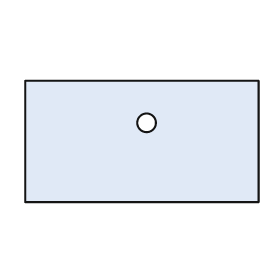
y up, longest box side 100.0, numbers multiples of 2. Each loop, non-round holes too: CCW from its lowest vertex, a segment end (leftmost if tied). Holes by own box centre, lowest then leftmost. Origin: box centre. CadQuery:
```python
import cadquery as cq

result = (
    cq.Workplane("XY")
    .moveTo(-50.0, -26.0)
    .lineTo(50.0, -26.0)
    .lineTo(50.0, 26.0)
    .lineTo(-50.0, 26.0)
    .close()
    .moveTo(2.0, 8.0)
    .circle(4.0)
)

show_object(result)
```